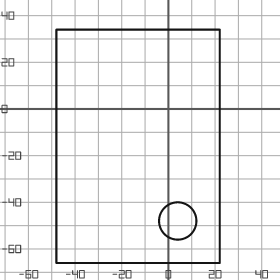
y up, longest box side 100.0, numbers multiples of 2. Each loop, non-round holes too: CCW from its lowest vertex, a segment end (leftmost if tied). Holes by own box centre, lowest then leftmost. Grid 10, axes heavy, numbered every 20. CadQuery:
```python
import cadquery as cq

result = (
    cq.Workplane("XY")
    .moveTo(-48.0, -66.0)
    .lineTo(22.0, -66.0)
    .lineTo(22.0, 34.0)
    .lineTo(-48.0, 34.0)
    .close()
    .moveTo(4.0, -48.0)
    .circle(8.0)
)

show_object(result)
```